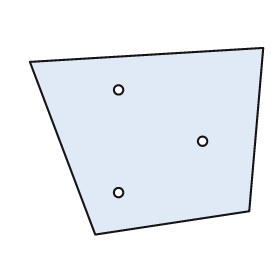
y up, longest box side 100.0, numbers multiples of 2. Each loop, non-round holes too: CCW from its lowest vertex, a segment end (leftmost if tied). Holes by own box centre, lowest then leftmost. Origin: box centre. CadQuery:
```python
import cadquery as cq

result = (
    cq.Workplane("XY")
    .moveTo(-22.0, -40.0)
    .lineTo(44.0, -30.0)
    .lineTo(50.0, 40.0)
    .lineTo(-50.0, 34.0)
    .close()
    .moveTo(-12.0, -22.0)
    .circle(2.0)
    .moveTo(24.0, 0.0)
    .circle(2.0)
    .moveTo(-12.0, 22.0)
    .circle(2.0)
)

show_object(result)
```